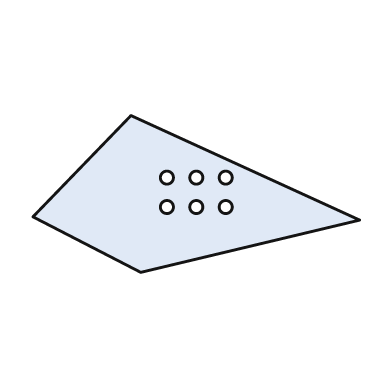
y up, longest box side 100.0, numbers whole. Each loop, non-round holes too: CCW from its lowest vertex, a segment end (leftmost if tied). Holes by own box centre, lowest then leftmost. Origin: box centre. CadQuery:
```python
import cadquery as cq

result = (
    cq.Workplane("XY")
    .moveTo(-17.0, -24.0)
    .lineTo(50.0, -8.0)
    .lineTo(-20.0, 24.0)
    .lineTo(-50.0, -7.0)
    .close()
    .moveTo(-9.0, -4.0)
    .circle(2.0)
    .moveTo(0.0, -4.0)
    .circle(2.0)
    .moveTo(9.0, -4.0)
    .circle(2.0)
    .moveTo(-9.0, 5.0)
    .circle(2.0)
    .moveTo(0.0, 5.0)
    .circle(2.0)
    .moveTo(9.0, 5.0)
    .circle(2.0)
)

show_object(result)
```